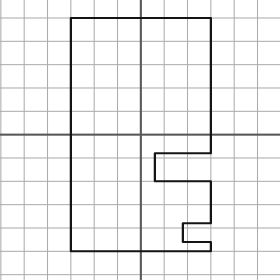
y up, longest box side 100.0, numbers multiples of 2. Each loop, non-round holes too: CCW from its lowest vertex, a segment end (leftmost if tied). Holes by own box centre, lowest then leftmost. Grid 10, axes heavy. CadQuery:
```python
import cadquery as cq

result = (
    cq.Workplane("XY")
    .moveTo(-30.0, -50.0)
    .lineTo(30.0, -50.0)
    .lineTo(30.0, -46.0)
    .lineTo(18.0, -46.0)
    .lineTo(18.0, -38.0)
    .lineTo(30.0, -38.0)
    .lineTo(30.0, -20.0)
    .lineTo(6.0, -20.0)
    .lineTo(6.0, -8.0)
    .lineTo(30.0, -8.0)
    .lineTo(30.0, 50.0)
    .lineTo(-30.0, 50.0)
    .close()
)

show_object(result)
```